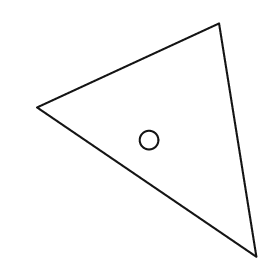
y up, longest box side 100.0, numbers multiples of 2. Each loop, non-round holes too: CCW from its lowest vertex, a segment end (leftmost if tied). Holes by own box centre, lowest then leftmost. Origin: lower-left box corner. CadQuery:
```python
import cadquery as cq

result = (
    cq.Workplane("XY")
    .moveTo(94.0, 0.0)
    .lineTo(78.0, 100.0)
    .lineTo(0.0, 64.0)
    .close()
    .moveTo(48.0, 50.0)
    .circle(4.0)
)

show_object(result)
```